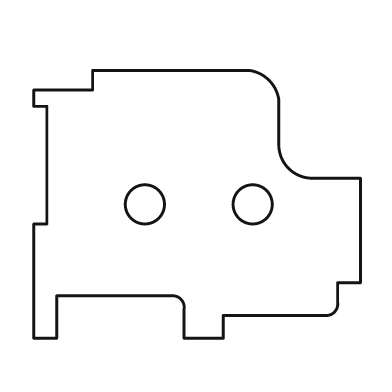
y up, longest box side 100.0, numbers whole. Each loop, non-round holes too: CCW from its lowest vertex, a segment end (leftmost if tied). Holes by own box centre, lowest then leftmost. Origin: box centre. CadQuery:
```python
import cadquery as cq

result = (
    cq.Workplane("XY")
    .moveTo(-50.0, -41.0)
    .lineTo(-43.0, -41.0)
    .lineTo(-43.0, -28.0)
    .lineTo(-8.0, -28.0)
    .threePointArc((-5.0, -29.0), (-4.0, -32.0))
    .lineTo(-4.0, -41.0)
    .lineTo(8.0, -41.0)
    .lineTo(8.0, -34.0)
    .lineTo(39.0, -34.0)
    .threePointArc((42.0, -33.0), (43.0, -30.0))
    .lineTo(43.0, -24.0)
    .lineTo(50.0, -24.0)
    .lineTo(50.0, 8.0)
    .lineTo(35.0, 8.0)
    .threePointArc((28.0, 11.0), (25.0, 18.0))
    .lineTo(25.0, 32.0)
    .threePointArc((22.0, 38.0), (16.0, 41.0))
    .lineTo(-32.0, 41.0)
    .lineTo(-32.0, 35.0)
    .lineTo(-50.0, 35.0)
    .lineTo(-50.0, 30.0)
    .lineTo(-46.0, 30.0)
    .lineTo(-46.0, -6.0)
    .lineTo(-50.0, -6.0)
    .close()
    .moveTo(-16.0, 0.0)
    .circle(6.0)
    .moveTo(17.0, 0.0)
    .circle(6.0)
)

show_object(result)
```